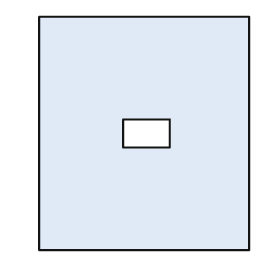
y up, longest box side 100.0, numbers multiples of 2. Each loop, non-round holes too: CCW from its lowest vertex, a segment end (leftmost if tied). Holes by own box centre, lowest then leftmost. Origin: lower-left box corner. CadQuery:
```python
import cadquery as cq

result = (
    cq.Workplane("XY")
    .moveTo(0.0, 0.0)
    .lineTo(90.0, 0.0)
    .lineTo(90.0, 100.0)
    .lineTo(0.0, 100.0)
    .close()
    .moveTo(36.0, 44.0)
    .lineTo(56.0, 44.0)
    .lineTo(56.0, 56.0)
    .lineTo(36.0, 56.0)
    .close()
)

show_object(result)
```